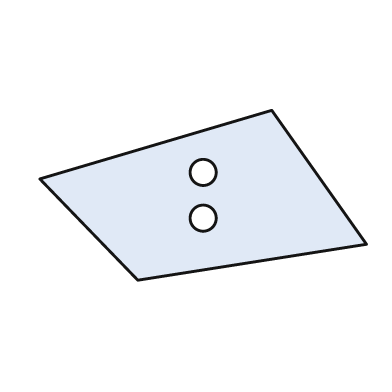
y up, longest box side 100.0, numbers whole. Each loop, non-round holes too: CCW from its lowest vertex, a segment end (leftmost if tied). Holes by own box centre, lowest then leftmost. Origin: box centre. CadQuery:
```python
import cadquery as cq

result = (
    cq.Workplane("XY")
    .moveTo(-20.0, -26.0)
    .lineTo(50.0, -15.0)
    .lineTo(21.0, 26.0)
    .lineTo(-50.0, 5.0)
    .close()
    .moveTo(0.0, -7.0)
    .circle(4.0)
    .moveTo(0.0, 7.0)
    .circle(4.0)
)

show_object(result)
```